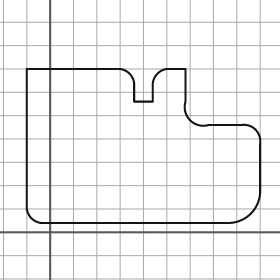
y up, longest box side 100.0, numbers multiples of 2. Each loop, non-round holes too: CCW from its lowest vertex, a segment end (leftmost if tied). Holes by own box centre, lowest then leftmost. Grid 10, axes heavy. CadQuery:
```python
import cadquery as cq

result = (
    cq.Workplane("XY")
    .moveTo(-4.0, 4.0)
    .lineTo(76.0, 4.0)
    .threePointArc((86.0, 8.0), (90.0, 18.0))
    .lineTo(90.0, 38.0)
    .threePointArc((88.0, 44.0), (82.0, 46.0))
    .lineTo(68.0, 46.0)
    .threePointArc((60.0, 48.0), (58.0, 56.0))
    .lineTo(58.0, 70.0)
    .lineTo(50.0, 70.0)
    .threePointArc((46.0, 68.0), (44.0, 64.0))
    .lineTo(44.0, 56.0)
    .lineTo(36.0, 56.0)
    .lineTo(36.0, 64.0)
    .threePointArc((34.0, 68.0), (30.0, 70.0))
    .lineTo(-10.0, 70.0)
    .lineTo(-10.0, 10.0)
    .threePointArc((-8.0, 6.0), (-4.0, 4.0))
    .close()
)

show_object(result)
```